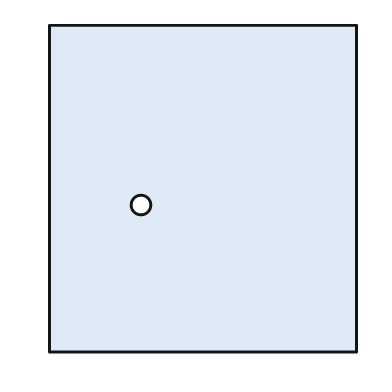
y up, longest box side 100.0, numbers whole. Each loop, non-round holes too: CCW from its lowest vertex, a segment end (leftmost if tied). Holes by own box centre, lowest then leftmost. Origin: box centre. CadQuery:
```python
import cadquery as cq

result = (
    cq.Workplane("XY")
    .moveTo(-47.0, -50.0)
    .lineTo(47.0, -50.0)
    .lineTo(47.0, 50.0)
    .lineTo(-47.0, 50.0)
    .close()
    .moveTo(-19.0, -5.0)
    .circle(3.0)
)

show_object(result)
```